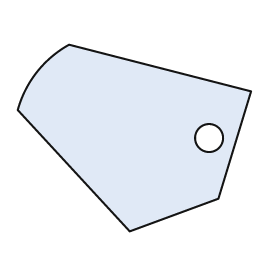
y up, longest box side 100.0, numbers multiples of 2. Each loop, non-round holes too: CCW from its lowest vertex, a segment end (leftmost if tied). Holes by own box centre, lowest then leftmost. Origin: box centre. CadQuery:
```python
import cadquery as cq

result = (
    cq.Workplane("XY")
    .moveTo(-2.0, -40.0)
    .lineTo(36.0, -26.0)
    .lineTo(50.0, 20.0)
    .lineTo(-28.0, 40.0)
    .threePointArc((-42.0, 28.0), (-50.0, 12.0))
    .close()
    .moveTo(32.0, 0.0)
    .circle(6.0)
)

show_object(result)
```